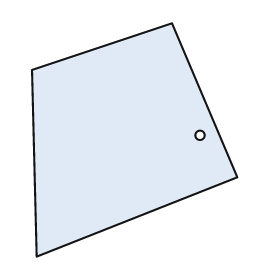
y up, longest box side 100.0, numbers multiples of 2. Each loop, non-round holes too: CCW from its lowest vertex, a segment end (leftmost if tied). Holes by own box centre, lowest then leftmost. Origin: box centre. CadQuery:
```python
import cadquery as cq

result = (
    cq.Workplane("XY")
    .moveTo(-42.0, -50.0)
    .lineTo(44.0, -16.0)
    .lineTo(16.0, 50.0)
    .lineTo(-44.0, 30.0)
    .close()
    .moveTo(28.0, 2.0)
    .circle(2.0)
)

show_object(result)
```